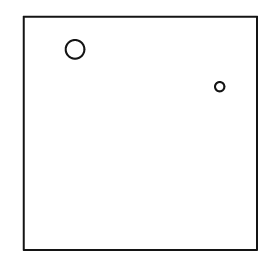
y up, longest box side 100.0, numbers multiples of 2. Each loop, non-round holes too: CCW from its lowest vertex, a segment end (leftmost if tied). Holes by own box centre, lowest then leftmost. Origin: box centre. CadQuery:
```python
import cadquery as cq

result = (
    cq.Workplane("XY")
    .moveTo(-50.0, -50.0)
    .lineTo(50.0, -50.0)
    .lineTo(50.0, 50.0)
    .lineTo(-50.0, 50.0)
    .close()
    .moveTo(34.0, 20.0)
    .circle(2.0)
    .moveTo(-28.0, 36.0)
    .circle(4.0)
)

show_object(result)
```